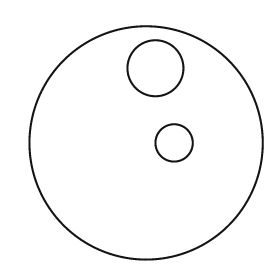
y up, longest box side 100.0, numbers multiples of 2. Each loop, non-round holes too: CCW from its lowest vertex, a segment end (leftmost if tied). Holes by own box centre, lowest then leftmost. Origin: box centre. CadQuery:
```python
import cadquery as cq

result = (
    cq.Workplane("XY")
    .moveTo(0.0, 0.0)
    .circle(50.0)
    .moveTo(12.0, 0.0)
    .circle(8.0)
    .moveTo(4.0, 32.0)
    .circle(12.0)
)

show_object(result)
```